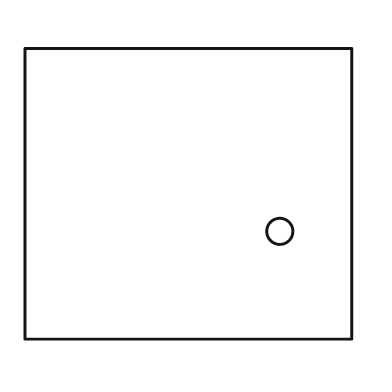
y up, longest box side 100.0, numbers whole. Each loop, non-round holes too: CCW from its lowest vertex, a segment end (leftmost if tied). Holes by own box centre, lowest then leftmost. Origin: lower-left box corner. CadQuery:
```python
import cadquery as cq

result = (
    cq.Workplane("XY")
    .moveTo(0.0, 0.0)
    .lineTo(100.0, 0.0)
    .lineTo(100.0, 89.0)
    .lineTo(0.0, 89.0)
    .close()
    .moveTo(78.0, 33.0)
    .circle(4.0)
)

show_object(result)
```